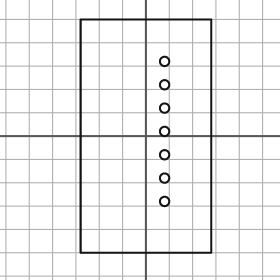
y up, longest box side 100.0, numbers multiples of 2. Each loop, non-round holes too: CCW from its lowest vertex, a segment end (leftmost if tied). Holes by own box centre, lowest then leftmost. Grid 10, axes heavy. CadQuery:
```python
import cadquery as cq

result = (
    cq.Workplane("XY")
    .moveTo(-28.0, -50.0)
    .lineTo(28.0, -50.0)
    .lineTo(28.0, 50.0)
    .lineTo(-28.0, 50.0)
    .close()
    .moveTo(8.0, -28.0)
    .circle(2.0)
    .moveTo(8.0, -18.0)
    .circle(2.0)
    .moveTo(8.0, -8.0)
    .circle(2.0)
    .moveTo(8.0, 2.0)
    .circle(2.0)
    .moveTo(8.0, 12.0)
    .circle(2.0)
    .moveTo(8.0, 22.0)
    .circle(2.0)
    .moveTo(8.0, 32.0)
    .circle(2.0)
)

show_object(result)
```